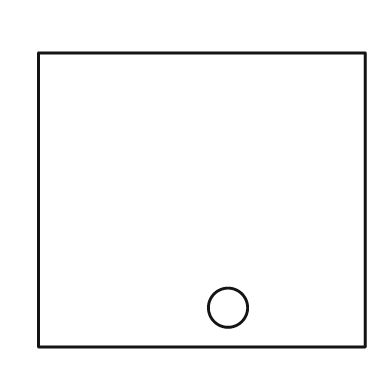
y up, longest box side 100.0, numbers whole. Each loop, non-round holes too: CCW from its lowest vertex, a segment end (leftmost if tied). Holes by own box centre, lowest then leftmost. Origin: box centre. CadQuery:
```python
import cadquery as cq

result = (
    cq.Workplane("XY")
    .moveTo(-50.0, -45.0)
    .lineTo(50.0, -45.0)
    .lineTo(50.0, 45.0)
    .lineTo(-50.0, 45.0)
    .close()
    .moveTo(8.0, -33.0)
    .circle(6.0)
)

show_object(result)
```